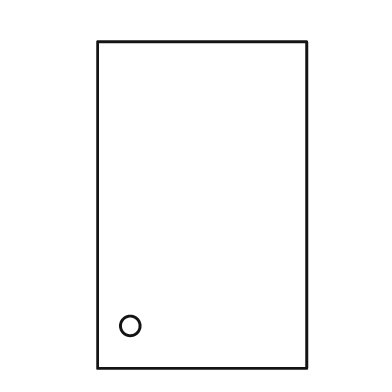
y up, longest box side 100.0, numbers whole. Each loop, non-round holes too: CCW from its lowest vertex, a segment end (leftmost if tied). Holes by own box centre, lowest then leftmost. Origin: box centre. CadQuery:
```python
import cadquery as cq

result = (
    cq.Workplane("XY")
    .moveTo(-32.0, -50.0)
    .lineTo(32.0, -50.0)
    .lineTo(32.0, 50.0)
    .lineTo(-32.0, 50.0)
    .close()
    .moveTo(-22.0, -37.0)
    .circle(3.0)
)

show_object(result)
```